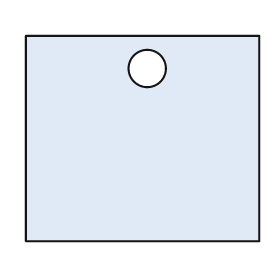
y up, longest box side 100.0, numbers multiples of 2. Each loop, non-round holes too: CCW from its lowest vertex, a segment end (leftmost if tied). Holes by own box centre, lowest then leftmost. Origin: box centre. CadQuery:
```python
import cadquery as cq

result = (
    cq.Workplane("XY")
    .moveTo(-50.0, -44.0)
    .lineTo(50.0, -44.0)
    .lineTo(50.0, 44.0)
    .lineTo(-50.0, 44.0)
    .close()
    .moveTo(2.0, 30.0)
    .circle(8.0)
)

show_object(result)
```